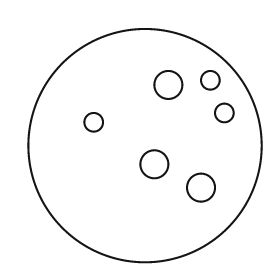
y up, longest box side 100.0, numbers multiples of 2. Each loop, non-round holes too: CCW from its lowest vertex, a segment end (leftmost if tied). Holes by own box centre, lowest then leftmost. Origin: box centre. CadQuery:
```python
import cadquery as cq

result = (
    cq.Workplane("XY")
    .moveTo(0.0, 0.0)
    .circle(50.0)
    .moveTo(24.0, -18.0)
    .circle(6.0)
    .moveTo(4.0, -8.0)
    .circle(6.0)
    .moveTo(-22.0, 10.0)
    .circle(4.0)
    .moveTo(34.0, 14.0)
    .circle(4.0)
    .moveTo(10.0, 26.0)
    .circle(6.0)
    .moveTo(28.0, 28.0)
    .circle(4.0)
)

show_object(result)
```